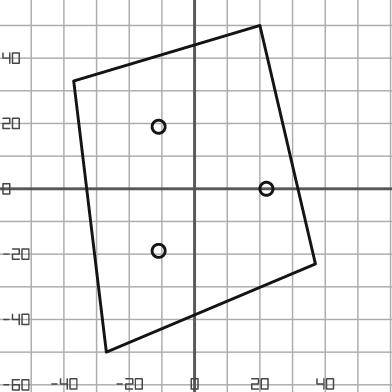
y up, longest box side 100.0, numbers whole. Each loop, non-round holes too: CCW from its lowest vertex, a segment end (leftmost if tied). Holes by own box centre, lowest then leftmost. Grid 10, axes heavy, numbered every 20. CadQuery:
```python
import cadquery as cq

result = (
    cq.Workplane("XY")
    .moveTo(-27.0, -50.0)
    .lineTo(37.0, -23.0)
    .lineTo(20.0, 50.0)
    .lineTo(-37.0, 33.0)
    .close()
    .moveTo(-11.0, -19.0)
    .circle(2.0)
    .moveTo(22.0, 0.0)
    .circle(2.0)
    .moveTo(-11.0, 19.0)
    .circle(2.0)
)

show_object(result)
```